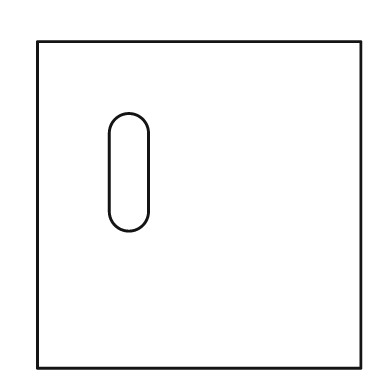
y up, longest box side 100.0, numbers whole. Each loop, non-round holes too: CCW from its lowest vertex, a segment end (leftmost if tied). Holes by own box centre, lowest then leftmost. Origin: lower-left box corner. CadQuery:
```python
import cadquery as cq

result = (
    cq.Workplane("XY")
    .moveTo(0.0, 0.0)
    .lineTo(99.0, 0.0)
    .lineTo(99.0, 100.0)
    .lineTo(0.0, 100.0)
    .close()
    .moveTo(22.0, 48.0)
    .threePointArc((28.0, 42.0), (34.0, 48.0))
    .lineTo(34.0, 72.0)
    .threePointArc((28.0, 78.0), (22.0, 72.0))
    .close()
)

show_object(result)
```